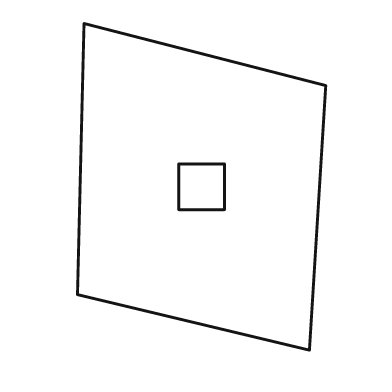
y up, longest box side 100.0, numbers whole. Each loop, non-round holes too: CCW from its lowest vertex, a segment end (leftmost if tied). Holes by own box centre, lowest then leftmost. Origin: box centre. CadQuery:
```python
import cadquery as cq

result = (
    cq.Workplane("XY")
    .moveTo(33.0, -50.0)
    .lineTo(38.0, 31.0)
    .lineTo(-36.0, 50.0)
    .lineTo(-38.0, -33.0)
    .close()
    .moveTo(-7.0, -7.0)
    .lineTo(7.0, -7.0)
    .lineTo(7.0, 7.0)
    .lineTo(-7.0, 7.0)
    .close()
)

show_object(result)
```